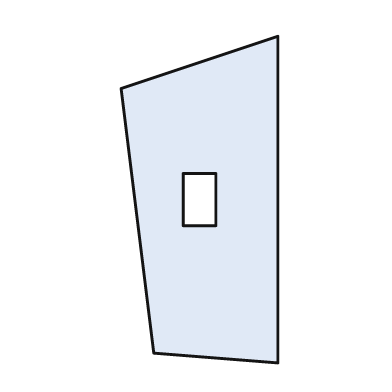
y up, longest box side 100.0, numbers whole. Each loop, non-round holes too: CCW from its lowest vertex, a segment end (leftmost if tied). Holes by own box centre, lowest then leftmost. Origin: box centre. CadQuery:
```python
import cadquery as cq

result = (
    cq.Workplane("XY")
    .moveTo(24.0, -50.0)
    .lineTo(24.0, 50.0)
    .lineTo(-24.0, 34.0)
    .lineTo(-14.0, -47.0)
    .close()
    .moveTo(-5.0, -8.0)
    .lineTo(5.0, -8.0)
    .lineTo(5.0, 8.0)
    .lineTo(-5.0, 8.0)
    .close()
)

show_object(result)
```